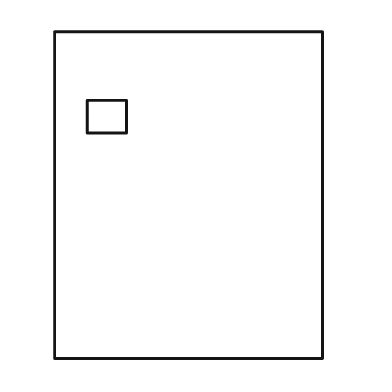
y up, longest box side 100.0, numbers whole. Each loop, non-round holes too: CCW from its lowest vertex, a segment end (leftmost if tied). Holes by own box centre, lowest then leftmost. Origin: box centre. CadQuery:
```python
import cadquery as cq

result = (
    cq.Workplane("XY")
    .moveTo(-41.0, -50.0)
    .lineTo(41.0, -50.0)
    .lineTo(41.0, 50.0)
    .lineTo(-41.0, 50.0)
    .close()
    .moveTo(-31.0, 19.0)
    .lineTo(-19.0, 19.0)
    .lineTo(-19.0, 29.0)
    .lineTo(-31.0, 29.0)
    .close()
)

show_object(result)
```